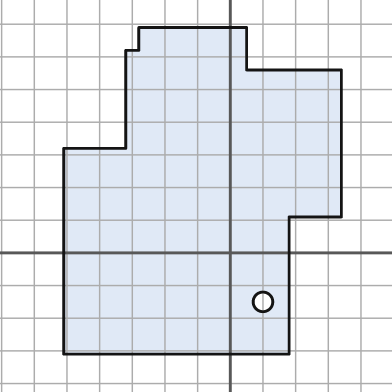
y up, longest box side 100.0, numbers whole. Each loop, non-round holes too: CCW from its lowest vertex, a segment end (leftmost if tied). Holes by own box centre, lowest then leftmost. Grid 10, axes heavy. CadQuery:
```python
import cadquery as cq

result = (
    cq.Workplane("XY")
    .moveTo(-51.0, -31.0)
    .lineTo(18.0, -31.0)
    .lineTo(18.0, 11.0)
    .lineTo(34.0, 11.0)
    .lineTo(34.0, 56.0)
    .lineTo(5.0, 56.0)
    .lineTo(5.0, 69.0)
    .lineTo(-28.0, 69.0)
    .lineTo(-28.0, 62.0)
    .lineTo(-32.0, 62.0)
    .lineTo(-32.0, 32.0)
    .lineTo(-51.0, 32.0)
    .close()
    .moveTo(10.0, -15.0)
    .circle(3.0)
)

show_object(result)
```